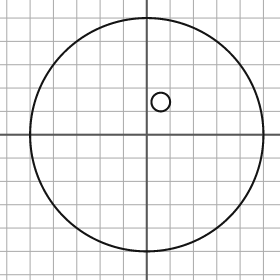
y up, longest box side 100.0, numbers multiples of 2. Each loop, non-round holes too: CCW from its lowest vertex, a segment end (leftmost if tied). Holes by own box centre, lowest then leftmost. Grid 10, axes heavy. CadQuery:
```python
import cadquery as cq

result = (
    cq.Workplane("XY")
    .moveTo(0.0, 0.0)
    .circle(50.0)
    .moveTo(6.0, 14.0)
    .circle(4.0)
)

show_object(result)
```